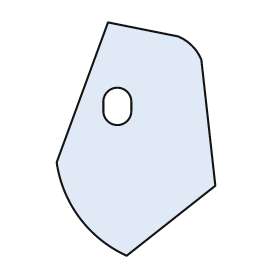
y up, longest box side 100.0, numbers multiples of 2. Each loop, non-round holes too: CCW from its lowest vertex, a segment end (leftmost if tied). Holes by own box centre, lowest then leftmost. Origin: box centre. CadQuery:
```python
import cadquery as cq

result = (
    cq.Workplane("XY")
    .moveTo(-4.0, -50.0)
    .lineTo(34.0, -20.0)
    .lineTo(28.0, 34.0)
    .threePointArc((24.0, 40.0), (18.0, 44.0))
    .lineTo(-12.0, 50.0)
    .lineTo(-34.0, -10.0)
    .threePointArc((-24.0, -34.0), (-4.0, -50.0))
    .close()
    .moveTo(-14.0, 12.0)
    .threePointArc((-8.0, 6.0), (-2.0, 12.0))
    .lineTo(-2.0, 16.0)
    .threePointArc((-8.0, 22.0), (-14.0, 16.0))
    .close()
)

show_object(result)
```